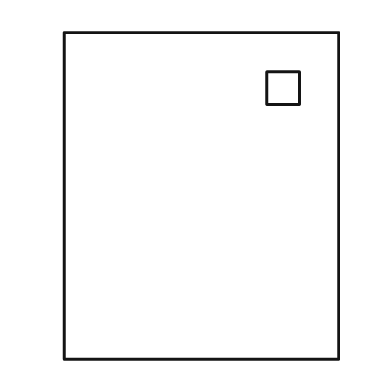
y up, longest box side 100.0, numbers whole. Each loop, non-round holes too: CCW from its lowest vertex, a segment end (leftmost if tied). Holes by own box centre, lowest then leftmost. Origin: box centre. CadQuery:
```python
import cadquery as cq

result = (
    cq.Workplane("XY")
    .moveTo(-42.0, -50.0)
    .lineTo(42.0, -50.0)
    .lineTo(42.0, 50.0)
    .lineTo(-42.0, 50.0)
    .close()
    .moveTo(20.0, 28.0)
    .lineTo(30.0, 28.0)
    .lineTo(30.0, 38.0)
    .lineTo(20.0, 38.0)
    .close()
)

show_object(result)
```